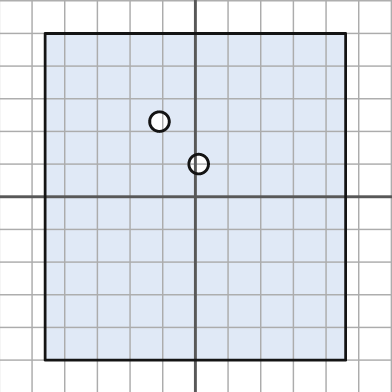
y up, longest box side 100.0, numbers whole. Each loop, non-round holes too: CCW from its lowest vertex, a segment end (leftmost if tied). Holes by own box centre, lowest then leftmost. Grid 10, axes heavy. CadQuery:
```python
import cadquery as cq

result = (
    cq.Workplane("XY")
    .moveTo(-46.0, -50.0)
    .lineTo(46.0, -50.0)
    .lineTo(46.0, 50.0)
    .lineTo(-46.0, 50.0)
    .close()
    .moveTo(1.0, 10.0)
    .circle(3.0)
    .moveTo(-11.0, 23.0)
    .circle(3.0)
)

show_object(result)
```